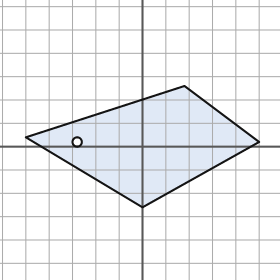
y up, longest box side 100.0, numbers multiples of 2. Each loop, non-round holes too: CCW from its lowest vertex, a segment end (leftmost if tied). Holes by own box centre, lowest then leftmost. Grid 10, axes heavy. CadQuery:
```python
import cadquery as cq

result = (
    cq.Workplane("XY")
    .moveTo(0.0, -26.0)
    .lineTo(50.0, 2.0)
    .lineTo(18.0, 26.0)
    .lineTo(-50.0, 4.0)
    .close()
    .moveTo(-28.0, 2.0)
    .circle(2.0)
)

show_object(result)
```